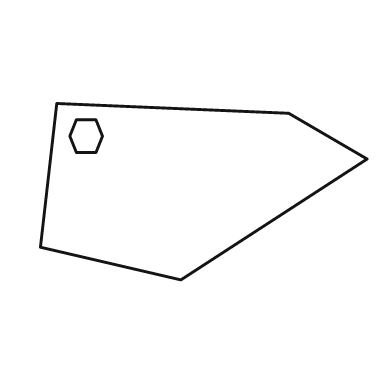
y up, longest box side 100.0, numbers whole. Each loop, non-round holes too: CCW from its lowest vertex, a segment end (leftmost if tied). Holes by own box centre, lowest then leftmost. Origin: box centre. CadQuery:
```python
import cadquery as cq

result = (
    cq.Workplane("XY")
    .moveTo(-7.0, -27.0)
    .lineTo(50.0, 10.0)
    .lineTo(26.0, 24.0)
    .lineTo(-45.0, 27.0)
    .lineTo(-50.0, -17.0)
    .close()
    .moveTo(-39.0, 12.0)
    .lineTo(-33.0, 12.0)
    .lineTo(-31.0, 17.0)
    .lineTo(-33.0, 22.0)
    .lineTo(-39.0, 22.0)
    .lineTo(-41.0, 17.0)
    .close()
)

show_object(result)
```